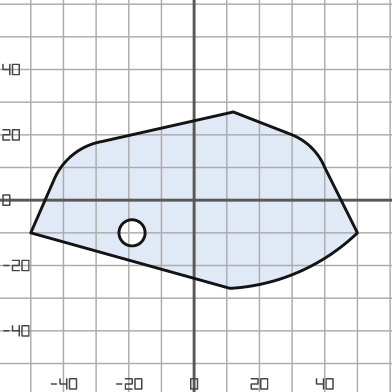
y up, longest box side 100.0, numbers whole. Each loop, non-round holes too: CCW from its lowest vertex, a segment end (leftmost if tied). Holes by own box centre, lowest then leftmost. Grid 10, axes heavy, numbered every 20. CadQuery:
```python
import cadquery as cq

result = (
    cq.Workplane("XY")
    .moveTo(11.0, -27.0)
    .threePointArc((32.0, -22.0), (50.0, -10.0))
    .lineTo(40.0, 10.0)
    .threePointArc((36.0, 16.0), (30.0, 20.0))
    .lineTo(12.0, 27.0)
    .lineTo(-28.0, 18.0)
    .threePointArc((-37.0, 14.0), (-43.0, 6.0))
    .lineTo(-50.0, -10.0)
    .close()
    .moveTo(-19.0, -10.0)
    .circle(4.0)
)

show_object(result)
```